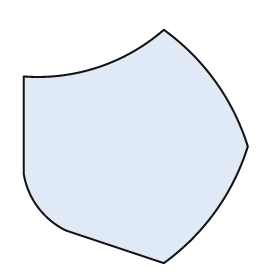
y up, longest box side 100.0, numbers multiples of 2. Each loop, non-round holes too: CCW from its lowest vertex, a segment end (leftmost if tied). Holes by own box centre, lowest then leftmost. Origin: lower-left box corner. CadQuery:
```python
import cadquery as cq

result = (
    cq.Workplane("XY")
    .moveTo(60.0, 0.0)
    .threePointArc((82.0, 22.0), (96.0, 50.0))
    .threePointArc((82.0, 78.0), (60.0, 100.0))
    .threePointArc((32.0, 84.0), (0.0, 80.0))
    .lineTo(0.0, 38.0)
    .threePointArc((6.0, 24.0), (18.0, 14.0))
    .close()
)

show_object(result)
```